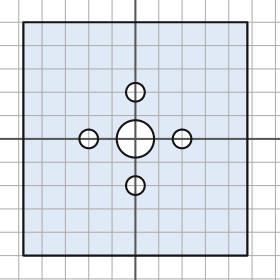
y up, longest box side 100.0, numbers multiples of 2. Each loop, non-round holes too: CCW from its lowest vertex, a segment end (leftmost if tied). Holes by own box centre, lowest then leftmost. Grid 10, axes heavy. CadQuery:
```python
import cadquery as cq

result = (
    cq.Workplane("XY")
    .moveTo(-48.0, -50.0)
    .lineTo(48.0, -50.0)
    .lineTo(48.0, 50.0)
    .lineTo(-48.0, 50.0)
    .close()
    .moveTo(0.0, -20.0)
    .circle(4.0)
    .moveTo(-20.0, 0.0)
    .circle(4.0)
    .moveTo(0.0, 0.0)
    .circle(8.0)
    .moveTo(20.0, 0.0)
    .circle(4.0)
    .moveTo(0.0, 20.0)
    .circle(4.0)
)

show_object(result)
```